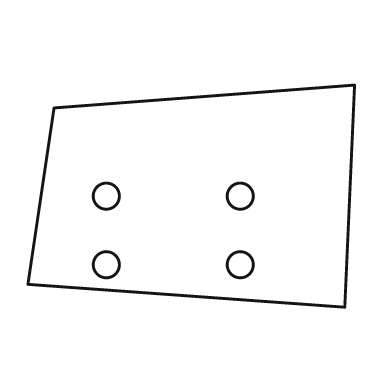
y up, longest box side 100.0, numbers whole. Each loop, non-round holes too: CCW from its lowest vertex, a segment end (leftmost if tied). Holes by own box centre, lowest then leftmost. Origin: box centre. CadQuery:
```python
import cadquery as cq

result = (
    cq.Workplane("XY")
    .moveTo(47.0, -34.0)
    .lineTo(50.0, 34.0)
    .lineTo(-42.0, 27.0)
    .lineTo(-50.0, -27.0)
    .close()
    .moveTo(-26.0, -21.0)
    .circle(4.0)
    .moveTo(15.0, -21.0)
    .circle(4.0)
    .moveTo(-26.0, 0.0)
    .circle(4.0)
    .moveTo(15.0, 0.0)
    .circle(4.0)
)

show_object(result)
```